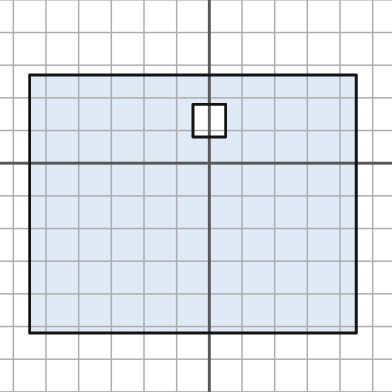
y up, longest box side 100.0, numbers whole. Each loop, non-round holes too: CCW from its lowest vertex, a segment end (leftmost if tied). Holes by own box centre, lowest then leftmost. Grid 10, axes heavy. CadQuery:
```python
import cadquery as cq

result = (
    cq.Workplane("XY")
    .moveTo(-55.0, -52.0)
    .lineTo(45.0, -52.0)
    .lineTo(45.0, 27.0)
    .lineTo(-55.0, 27.0)
    .close()
    .moveTo(-5.0, 8.0)
    .lineTo(5.0, 8.0)
    .lineTo(5.0, 18.0)
    .lineTo(-5.0, 18.0)
    .close()
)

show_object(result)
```